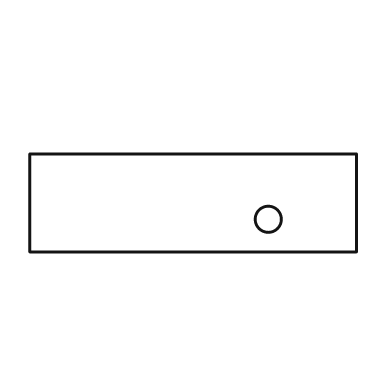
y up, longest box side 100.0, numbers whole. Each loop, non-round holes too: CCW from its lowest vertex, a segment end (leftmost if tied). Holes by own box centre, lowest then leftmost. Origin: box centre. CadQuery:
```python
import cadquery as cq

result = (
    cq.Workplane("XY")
    .moveTo(-50.0, -15.0)
    .lineTo(50.0, -15.0)
    .lineTo(50.0, 15.0)
    .lineTo(-50.0, 15.0)
    .close()
    .moveTo(23.0, -5.0)
    .circle(4.0)
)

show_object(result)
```